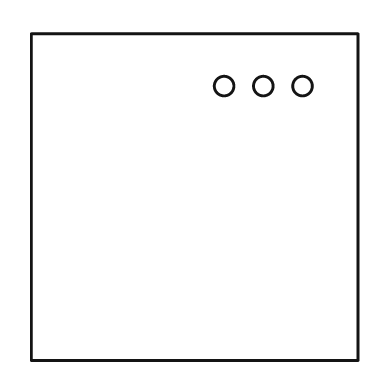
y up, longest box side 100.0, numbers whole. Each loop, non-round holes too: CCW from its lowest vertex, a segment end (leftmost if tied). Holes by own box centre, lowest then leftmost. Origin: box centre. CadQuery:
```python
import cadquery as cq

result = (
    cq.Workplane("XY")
    .moveTo(-50.0, -50.0)
    .lineTo(50.0, -50.0)
    .lineTo(50.0, 50.0)
    .lineTo(-50.0, 50.0)
    .close()
    .moveTo(9.0, 34.0)
    .circle(3.0)
    .moveTo(21.0, 34.0)
    .circle(3.0)
    .moveTo(33.0, 34.0)
    .circle(3.0)
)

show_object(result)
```